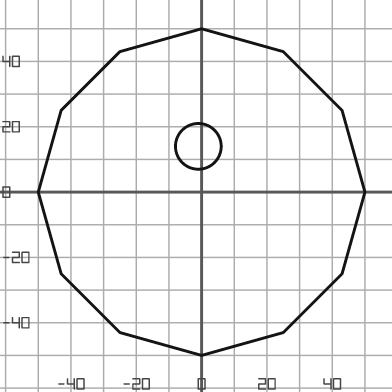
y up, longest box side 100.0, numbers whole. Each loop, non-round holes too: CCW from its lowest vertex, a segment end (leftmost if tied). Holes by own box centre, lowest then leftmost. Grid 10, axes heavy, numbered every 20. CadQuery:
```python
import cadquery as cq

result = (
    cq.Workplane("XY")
    .moveTo(0.0, -50.0)
    .lineTo(25.0, -43.0)
    .lineTo(43.0, -25.0)
    .lineTo(50.0, 0.0)
    .lineTo(43.0, 25.0)
    .lineTo(25.0, 43.0)
    .lineTo(0.0, 50.0)
    .lineTo(-25.0, 43.0)
    .lineTo(-43.0, 25.0)
    .lineTo(-50.0, 0.0)
    .lineTo(-43.0, -25.0)
    .lineTo(-25.0, -43.0)
    .close()
    .moveTo(-1.0, 14.0)
    .circle(7.0)
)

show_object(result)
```